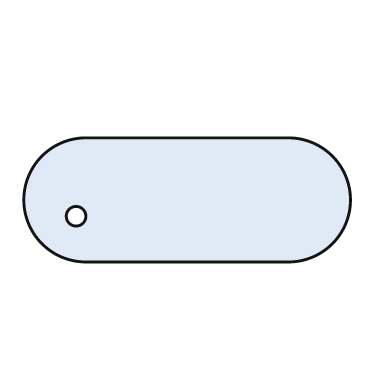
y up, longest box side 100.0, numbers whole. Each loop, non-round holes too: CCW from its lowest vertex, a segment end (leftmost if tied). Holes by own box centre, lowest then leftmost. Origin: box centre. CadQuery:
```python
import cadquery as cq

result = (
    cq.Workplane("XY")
    .moveTo(-31.0, -19.0)
    .lineTo(31.0, -19.0)
    .threePointArc((50.0, 0.0), (31.0, 19.0))
    .lineTo(-31.0, 19.0)
    .threePointArc((-50.0, 0.0), (-31.0, -19.0))
    .close()
    .moveTo(-34.0, -5.0)
    .circle(3.0)
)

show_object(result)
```